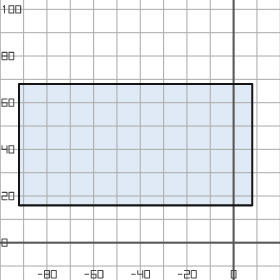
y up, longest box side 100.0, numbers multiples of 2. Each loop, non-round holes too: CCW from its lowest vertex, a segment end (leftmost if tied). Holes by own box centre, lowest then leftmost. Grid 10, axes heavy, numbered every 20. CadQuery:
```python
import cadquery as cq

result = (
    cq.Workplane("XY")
    .moveTo(-92.0, 16.0)
    .lineTo(8.0, 16.0)
    .lineTo(8.0, 68.0)
    .lineTo(-92.0, 68.0)
    .close()
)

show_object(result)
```